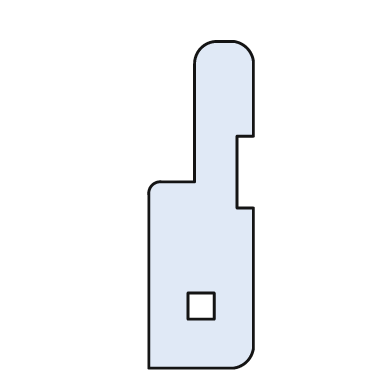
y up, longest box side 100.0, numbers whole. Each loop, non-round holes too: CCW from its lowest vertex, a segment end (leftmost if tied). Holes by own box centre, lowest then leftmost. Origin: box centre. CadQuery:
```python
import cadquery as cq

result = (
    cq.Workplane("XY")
    .moveTo(-16.0, -50.0)
    .lineTo(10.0, -50.0)
    .threePointArc((14.0, -48.0), (16.0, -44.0))
    .lineTo(16.0, -1.0)
    .lineTo(11.0, -1.0)
    .lineTo(11.0, 21.0)
    .lineTo(16.0, 21.0)
    .lineTo(16.0, 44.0)
    .threePointArc((14.0, 48.0), (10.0, 50.0))
    .lineTo(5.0, 50.0)
    .threePointArc((0.0, 48.0), (-2.0, 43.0))
    .lineTo(-2.0, 7.0)
    .lineTo(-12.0, 7.0)
    .threePointArc((-15.0, 6.0), (-16.0, 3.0))
    .close()
    .moveTo(-4.0, -35.0)
    .lineTo(4.0, -35.0)
    .lineTo(4.0, -27.0)
    .lineTo(-4.0, -27.0)
    .close()
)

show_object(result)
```